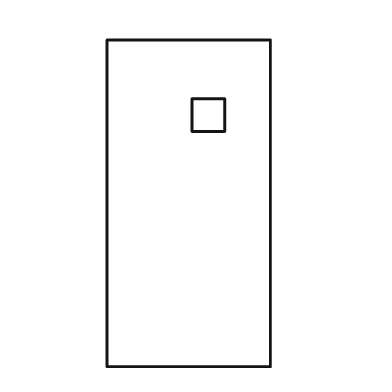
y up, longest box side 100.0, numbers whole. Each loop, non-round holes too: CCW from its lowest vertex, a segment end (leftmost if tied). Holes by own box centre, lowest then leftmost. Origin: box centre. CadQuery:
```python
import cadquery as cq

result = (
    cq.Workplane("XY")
    .moveTo(-25.0, -50.0)
    .lineTo(25.0, -50.0)
    .lineTo(25.0, 50.0)
    .lineTo(-25.0, 50.0)
    .close()
    .moveTo(1.0, 22.0)
    .lineTo(11.0, 22.0)
    .lineTo(11.0, 32.0)
    .lineTo(1.0, 32.0)
    .close()
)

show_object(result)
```